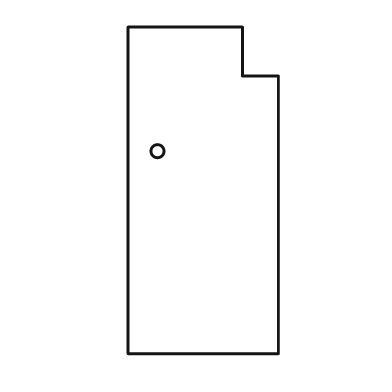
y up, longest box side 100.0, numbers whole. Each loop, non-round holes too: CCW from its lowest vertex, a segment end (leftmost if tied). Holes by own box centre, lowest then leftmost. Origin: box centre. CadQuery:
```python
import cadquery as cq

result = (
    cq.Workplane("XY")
    .moveTo(-23.0, -50.0)
    .lineTo(23.0, -50.0)
    .lineTo(23.0, 35.0)
    .lineTo(12.0, 35.0)
    .lineTo(12.0, 50.0)
    .lineTo(-23.0, 50.0)
    .close()
    .moveTo(-14.0, 12.0)
    .circle(2.0)
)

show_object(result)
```